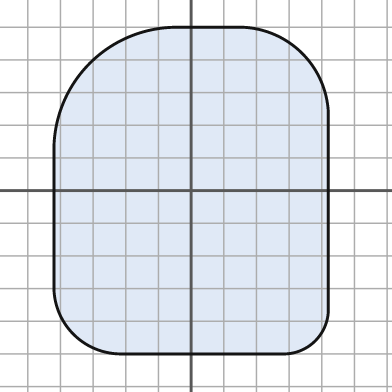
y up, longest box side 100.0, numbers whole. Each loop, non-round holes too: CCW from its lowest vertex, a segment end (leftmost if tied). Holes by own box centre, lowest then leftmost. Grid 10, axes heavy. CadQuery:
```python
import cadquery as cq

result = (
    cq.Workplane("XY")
    .moveTo(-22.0, -50.0)
    .lineTo(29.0, -50.0)
    .threePointArc((38.0, -46.0), (42.0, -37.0))
    .lineTo(42.0, 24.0)
    .threePointArc((34.0, 42.0), (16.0, 50.0))
    .lineTo(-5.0, 50.0)
    .threePointArc((-31.0, 39.0), (-42.0, 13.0))
    .lineTo(-42.0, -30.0)
    .threePointArc((-36.0, -44.0), (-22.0, -50.0))
    .close()
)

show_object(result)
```